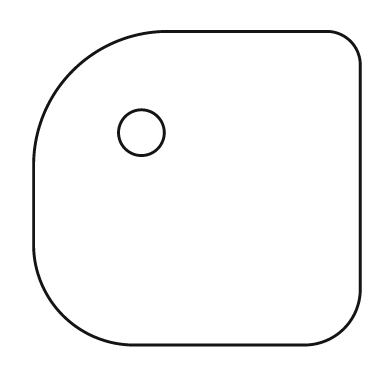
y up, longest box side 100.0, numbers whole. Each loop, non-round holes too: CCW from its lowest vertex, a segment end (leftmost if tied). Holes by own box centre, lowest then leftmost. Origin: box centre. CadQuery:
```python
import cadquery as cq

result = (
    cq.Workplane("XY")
    .moveTo(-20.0, -48.0)
    .lineTo(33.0, -48.0)
    .threePointArc((45.0, -43.0), (50.0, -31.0))
    .lineTo(50.0, 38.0)
    .threePointArc((47.0, 45.0), (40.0, 48.0))
    .lineTo(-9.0, 48.0)
    .threePointArc((-38.0, 36.0), (-50.0, 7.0))
    .lineTo(-50.0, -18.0)
    .threePointArc((-41.0, -39.0), (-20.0, -48.0))
    .close()
    .moveTo(-17.0, 17.0)
    .circle(7.0)
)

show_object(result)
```